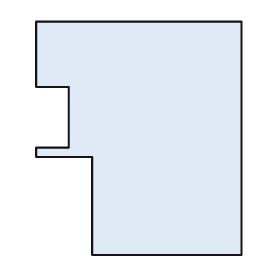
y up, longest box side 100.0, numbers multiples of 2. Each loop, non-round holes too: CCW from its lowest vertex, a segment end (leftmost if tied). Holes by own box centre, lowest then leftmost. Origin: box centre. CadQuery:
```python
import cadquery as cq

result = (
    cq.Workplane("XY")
    .moveTo(-20.0, -50.0)
    .lineTo(44.0, -50.0)
    .lineTo(44.0, 50.0)
    .lineTo(-44.0, 50.0)
    .lineTo(-44.0, 22.0)
    .lineTo(-30.0, 22.0)
    .lineTo(-30.0, -4.0)
    .lineTo(-44.0, -4.0)
    .lineTo(-44.0, -8.0)
    .lineTo(-20.0, -8.0)
    .close()
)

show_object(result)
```